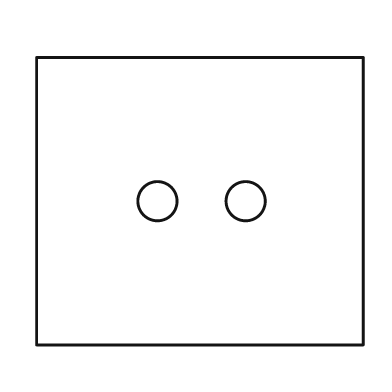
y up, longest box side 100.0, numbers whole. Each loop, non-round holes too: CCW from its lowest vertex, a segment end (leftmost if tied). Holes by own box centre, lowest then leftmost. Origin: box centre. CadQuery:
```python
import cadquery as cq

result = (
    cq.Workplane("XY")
    .moveTo(-50.0, -44.0)
    .lineTo(50.0, -44.0)
    .lineTo(50.0, 44.0)
    .lineTo(-50.0, 44.0)
    .close()
    .moveTo(-13.0, 0.0)
    .circle(6.0)
    .moveTo(14.0, 0.0)
    .circle(6.0)
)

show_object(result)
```